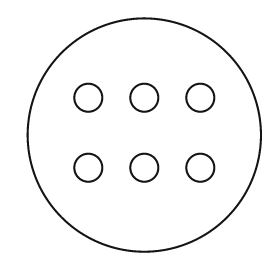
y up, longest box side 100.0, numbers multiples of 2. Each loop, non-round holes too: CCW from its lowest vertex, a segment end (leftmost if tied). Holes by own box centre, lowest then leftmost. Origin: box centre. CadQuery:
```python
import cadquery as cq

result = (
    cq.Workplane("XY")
    .moveTo(0.0, 0.0)
    .circle(50.0)
    .moveTo(-24.0, -14.0)
    .circle(6.0)
    .moveTo(0.0, -14.0)
    .circle(6.0)
    .moveTo(24.0, -14.0)
    .circle(6.0)
    .moveTo(-24.0, 16.0)
    .circle(6.0)
    .moveTo(0.0, 16.0)
    .circle(6.0)
    .moveTo(24.0, 16.0)
    .circle(6.0)
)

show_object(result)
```